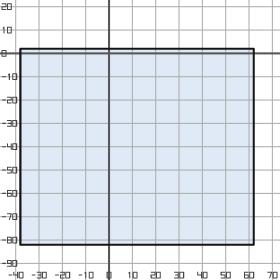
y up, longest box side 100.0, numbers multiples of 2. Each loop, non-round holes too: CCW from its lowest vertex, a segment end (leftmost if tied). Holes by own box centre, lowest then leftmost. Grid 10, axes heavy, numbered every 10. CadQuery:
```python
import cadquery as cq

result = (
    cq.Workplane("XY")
    .moveTo(-38.0, -82.0)
    .lineTo(62.0, -82.0)
    .lineTo(62.0, 2.0)
    .lineTo(-38.0, 2.0)
    .close()
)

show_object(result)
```